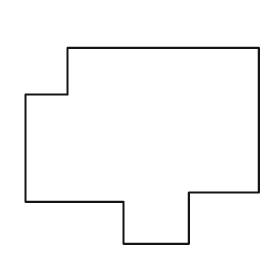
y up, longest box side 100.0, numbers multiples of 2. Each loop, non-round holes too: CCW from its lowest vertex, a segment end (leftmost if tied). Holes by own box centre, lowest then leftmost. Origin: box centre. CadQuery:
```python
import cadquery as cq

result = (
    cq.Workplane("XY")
    .moveTo(-8.0, -42.0)
    .lineTo(20.0, -42.0)
    .lineTo(20.0, -20.0)
    .lineTo(50.0, -20.0)
    .lineTo(50.0, 42.0)
    .lineTo(-32.0, 42.0)
    .lineTo(-32.0, 22.0)
    .lineTo(-50.0, 22.0)
    .lineTo(-50.0, -24.0)
    .lineTo(-8.0, -24.0)
    .close()
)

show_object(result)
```